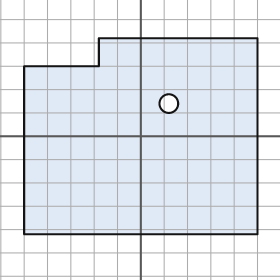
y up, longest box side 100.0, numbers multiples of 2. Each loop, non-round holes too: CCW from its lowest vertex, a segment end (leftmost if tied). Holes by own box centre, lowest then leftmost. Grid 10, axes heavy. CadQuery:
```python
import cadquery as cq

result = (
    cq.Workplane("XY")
    .moveTo(-50.0, -42.0)
    .lineTo(50.0, -42.0)
    .lineTo(50.0, 42.0)
    .lineTo(-18.0, 42.0)
    .lineTo(-18.0, 30.0)
    .lineTo(-50.0, 30.0)
    .close()
    .moveTo(12.0, 14.0)
    .circle(4.0)
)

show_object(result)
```